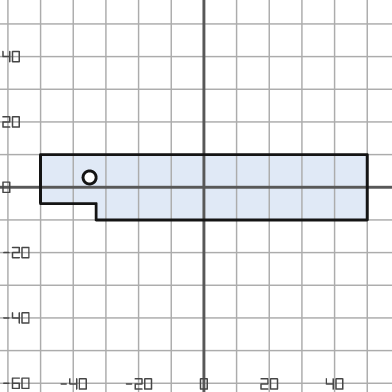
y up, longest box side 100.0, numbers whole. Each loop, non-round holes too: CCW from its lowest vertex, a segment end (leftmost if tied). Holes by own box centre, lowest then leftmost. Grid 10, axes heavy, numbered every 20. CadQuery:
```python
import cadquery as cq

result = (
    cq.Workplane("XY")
    .moveTo(-33.0, -10.0)
    .lineTo(50.0, -10.0)
    .lineTo(50.0, 10.0)
    .lineTo(-50.0, 10.0)
    .lineTo(-50.0, -5.0)
    .lineTo(-33.0, -5.0)
    .close()
    .moveTo(-35.0, 3.0)
    .circle(2.0)
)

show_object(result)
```